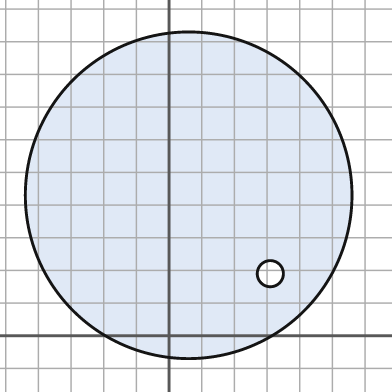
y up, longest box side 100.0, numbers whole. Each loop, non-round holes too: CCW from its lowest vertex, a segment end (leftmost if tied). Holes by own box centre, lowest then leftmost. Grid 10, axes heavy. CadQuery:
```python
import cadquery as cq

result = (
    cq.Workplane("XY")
    .moveTo(6.0, 43.0)
    .circle(50.0)
    .moveTo(31.0, 19.0)
    .circle(4.0)
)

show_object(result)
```